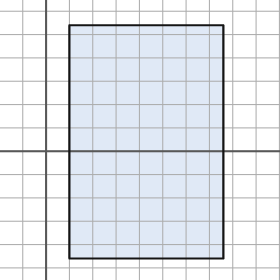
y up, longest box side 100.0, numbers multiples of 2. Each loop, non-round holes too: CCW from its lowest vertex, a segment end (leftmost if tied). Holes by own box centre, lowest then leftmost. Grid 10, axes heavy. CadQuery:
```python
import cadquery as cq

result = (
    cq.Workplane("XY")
    .moveTo(10.0, -46.0)
    .lineTo(76.0, -46.0)
    .lineTo(76.0, 54.0)
    .lineTo(10.0, 54.0)
    .close()
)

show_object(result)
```